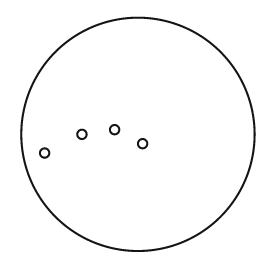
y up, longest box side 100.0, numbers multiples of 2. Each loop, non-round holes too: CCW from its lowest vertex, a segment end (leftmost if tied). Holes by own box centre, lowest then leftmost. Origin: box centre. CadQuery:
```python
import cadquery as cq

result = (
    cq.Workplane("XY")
    .moveTo(0.0, 0.0)
    .circle(50.0)
    .moveTo(-40.0, -8.0)
    .circle(2.0)
    .moveTo(2.0, -4.0)
    .circle(2.0)
    .moveTo(-24.0, 0.0)
    .circle(2.0)
    .moveTo(-10.0, 2.0)
    .circle(2.0)
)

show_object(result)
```